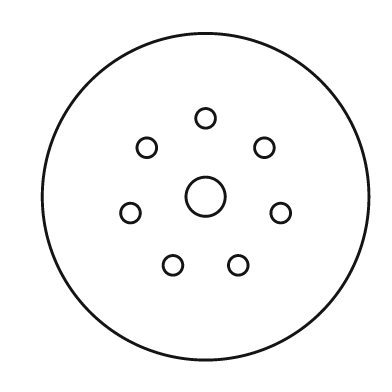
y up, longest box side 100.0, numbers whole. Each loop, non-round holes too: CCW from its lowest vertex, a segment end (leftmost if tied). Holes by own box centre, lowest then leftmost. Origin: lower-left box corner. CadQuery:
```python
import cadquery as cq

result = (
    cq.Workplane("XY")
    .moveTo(50.0, 50.0)
    .circle(50.0)
    .moveTo(40.0, 29.0)
    .circle(3.0)
    .moveTo(60.0, 29.0)
    .circle(3.0)
    .moveTo(27.0, 45.0)
    .circle(3.0)
    .moveTo(73.0, 45.0)
    .circle(3.0)
    .moveTo(50.0, 50.0)
    .circle(6.0)
    .moveTo(32.0, 65.0)
    .circle(3.0)
    .moveTo(68.0, 65.0)
    .circle(3.0)
    .moveTo(50.0, 74.0)
    .circle(3.0)
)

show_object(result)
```